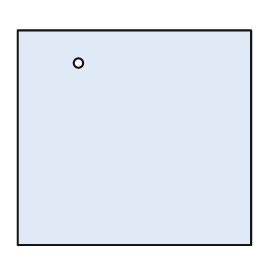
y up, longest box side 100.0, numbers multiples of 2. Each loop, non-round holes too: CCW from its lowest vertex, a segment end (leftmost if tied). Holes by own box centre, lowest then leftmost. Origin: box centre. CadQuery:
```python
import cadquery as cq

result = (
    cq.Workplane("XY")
    .moveTo(-50.0, -46.0)
    .lineTo(50.0, -46.0)
    .lineTo(50.0, 46.0)
    .lineTo(-50.0, 46.0)
    .close()
    .moveTo(-24.0, 32.0)
    .circle(2.0)
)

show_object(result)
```